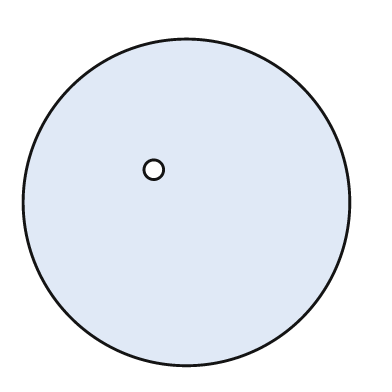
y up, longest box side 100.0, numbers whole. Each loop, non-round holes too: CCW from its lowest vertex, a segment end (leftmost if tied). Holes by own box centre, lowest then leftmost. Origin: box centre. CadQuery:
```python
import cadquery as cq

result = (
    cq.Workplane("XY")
    .moveTo(0.0, 0.0)
    .circle(50.0)
    .moveTo(-10.0, 10.0)
    .circle(3.0)
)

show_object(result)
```